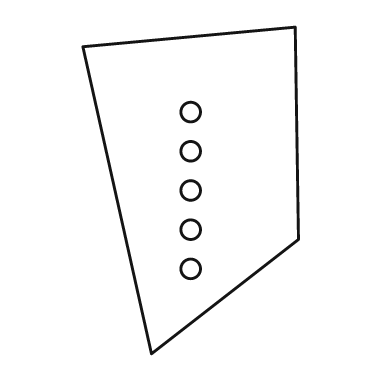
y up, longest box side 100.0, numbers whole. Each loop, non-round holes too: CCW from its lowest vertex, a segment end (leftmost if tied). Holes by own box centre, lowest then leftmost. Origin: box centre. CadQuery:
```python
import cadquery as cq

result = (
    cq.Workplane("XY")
    .moveTo(-12.0, -50.0)
    .lineTo(33.0, -15.0)
    .lineTo(32.0, 50.0)
    .lineTo(-33.0, 44.0)
    .close()
    .moveTo(0.0, -24.0)
    .circle(3.0)
    .moveTo(0.0, -12.0)
    .circle(3.0)
    .moveTo(0.0, 0.0)
    .circle(3.0)
    .moveTo(0.0, 12.0)
    .circle(3.0)
    .moveTo(0.0, 24.0)
    .circle(3.0)
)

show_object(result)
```